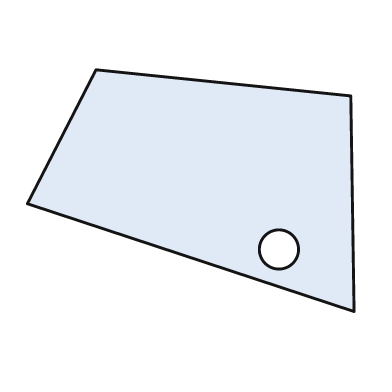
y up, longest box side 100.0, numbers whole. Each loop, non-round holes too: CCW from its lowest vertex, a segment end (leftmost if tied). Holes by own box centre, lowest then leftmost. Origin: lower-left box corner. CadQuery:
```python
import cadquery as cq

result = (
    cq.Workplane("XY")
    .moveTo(100.0, 0.0)
    .lineTo(99.0, 66.0)
    .lineTo(21.0, 74.0)
    .lineTo(0.0, 33.0)
    .close()
    .moveTo(77.0, 19.0)
    .circle(6.0)
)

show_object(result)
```